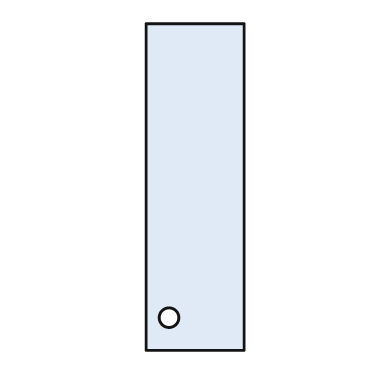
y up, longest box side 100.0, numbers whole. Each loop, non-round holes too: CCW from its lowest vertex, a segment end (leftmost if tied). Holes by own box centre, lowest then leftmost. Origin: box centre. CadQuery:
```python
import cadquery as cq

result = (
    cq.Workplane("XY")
    .moveTo(-15.0, -50.0)
    .lineTo(15.0, -50.0)
    .lineTo(15.0, 50.0)
    .lineTo(-15.0, 50.0)
    .close()
    .moveTo(-8.0, -40.0)
    .circle(3.0)
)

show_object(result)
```